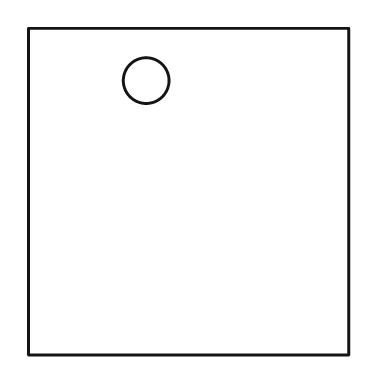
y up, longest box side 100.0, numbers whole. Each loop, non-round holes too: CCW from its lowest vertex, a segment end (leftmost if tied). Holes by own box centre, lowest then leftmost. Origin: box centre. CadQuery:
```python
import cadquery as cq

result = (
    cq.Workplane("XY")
    .moveTo(-49.0, -50.0)
    .lineTo(49.0, -50.0)
    .lineTo(49.0, 50.0)
    .lineTo(-49.0, 50.0)
    .close()
    .moveTo(-13.0, 34.0)
    .circle(7.0)
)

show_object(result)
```